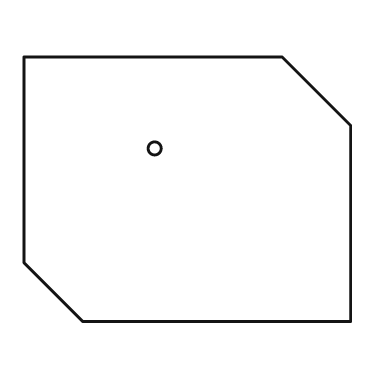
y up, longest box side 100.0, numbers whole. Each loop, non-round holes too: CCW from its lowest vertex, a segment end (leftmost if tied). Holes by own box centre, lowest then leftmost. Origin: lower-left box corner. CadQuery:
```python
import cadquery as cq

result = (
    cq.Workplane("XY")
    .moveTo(18.0, 0.0)
    .lineTo(100.0, 0.0)
    .lineTo(100.0, 60.0)
    .lineTo(79.0, 81.0)
    .lineTo(0.0, 81.0)
    .lineTo(0.0, 18.0)
    .close()
    .moveTo(40.0, 53.0)
    .circle(2.0)
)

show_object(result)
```